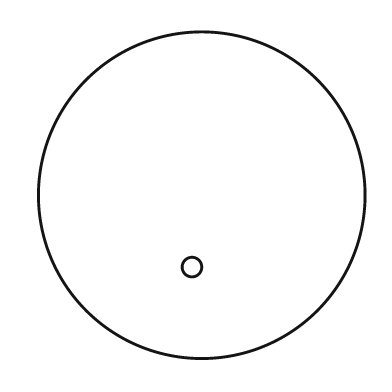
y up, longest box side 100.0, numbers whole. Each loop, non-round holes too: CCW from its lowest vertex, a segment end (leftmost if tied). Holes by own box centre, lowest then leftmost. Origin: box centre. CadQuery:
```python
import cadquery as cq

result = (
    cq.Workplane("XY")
    .moveTo(0.0, 0.0)
    .circle(50.0)
    .moveTo(-3.0, -22.0)
    .circle(3.0)
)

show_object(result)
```